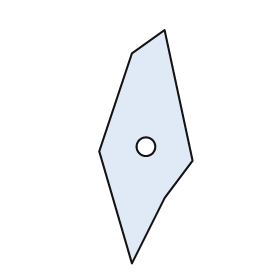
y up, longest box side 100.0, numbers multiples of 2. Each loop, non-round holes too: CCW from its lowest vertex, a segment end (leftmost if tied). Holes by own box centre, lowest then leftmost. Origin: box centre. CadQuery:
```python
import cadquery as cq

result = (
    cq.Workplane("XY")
    .moveTo(-6.0, -50.0)
    .lineTo(8.0, -22.0)
    .lineTo(20.0, -6.0)
    .lineTo(8.0, 50.0)
    .lineTo(-6.0, 40.0)
    .lineTo(-20.0, -2.0)
    .close()
    .moveTo(0.0, 0.0)
    .circle(4.0)
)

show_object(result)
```